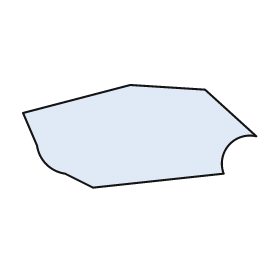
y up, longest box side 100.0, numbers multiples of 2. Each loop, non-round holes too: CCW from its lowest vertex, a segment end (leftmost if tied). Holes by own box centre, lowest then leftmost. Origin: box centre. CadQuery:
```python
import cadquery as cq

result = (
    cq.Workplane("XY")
    .moveTo(-20.0, -22.0)
    .lineTo(36.0, -16.0)
    .threePointArc((38.0, -4.0), (50.0, 0.0))
    .lineTo(28.0, 20.0)
    .lineTo(-4.0, 22.0)
    .lineTo(-50.0, 10.0)
    .lineTo(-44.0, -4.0)
    .threePointArc((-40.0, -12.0), (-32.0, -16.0))
    .close()
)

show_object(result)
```